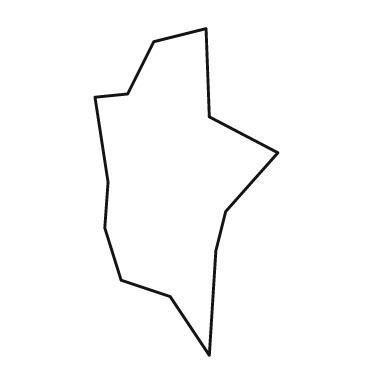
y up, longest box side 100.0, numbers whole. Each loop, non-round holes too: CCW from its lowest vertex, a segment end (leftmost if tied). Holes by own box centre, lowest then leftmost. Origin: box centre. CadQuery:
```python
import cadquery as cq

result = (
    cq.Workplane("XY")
    .moveTo(7.0, -50.0)
    .lineTo(9.0, -18.0)
    .lineTo(12.0, -6.0)
    .lineTo(28.0, 12.0)
    .lineTo(7.0, 23.0)
    .lineTo(6.0, 50.0)
    .lineTo(-10.0, 46.0)
    .lineTo(-18.0, 30.0)
    .lineTo(-28.0, 29.0)
    .lineTo(-24.0, 3.0)
    .lineTo(-25.0, -11.0)
    .lineTo(-20.0, -27.0)
    .lineTo(-5.0, -32.0)
    .close()
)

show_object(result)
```